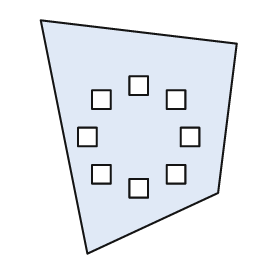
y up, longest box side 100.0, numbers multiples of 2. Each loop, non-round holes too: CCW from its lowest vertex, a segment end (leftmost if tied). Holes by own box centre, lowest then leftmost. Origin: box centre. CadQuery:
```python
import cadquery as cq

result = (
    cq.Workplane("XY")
    .moveTo(-22.0, -50.0)
    .lineTo(34.0, -24.0)
    .lineTo(42.0, 40.0)
    .lineTo(-42.0, 50.0)
    .close()
    .moveTo(-4.0, -26.0)
    .lineTo(4.0, -26.0)
    .lineTo(4.0, -18.0)
    .lineTo(-4.0, -18.0)
    .close()
    .moveTo(-20.0, -20.0)
    .lineTo(-12.0, -20.0)
    .lineTo(-12.0, -12.0)
    .lineTo(-20.0, -12.0)
    .close()
    .moveTo(12.0, -20.0)
    .lineTo(20.0, -20.0)
    .lineTo(20.0, -12.0)
    .lineTo(12.0, -12.0)
    .close()
    .moveTo(-26.0, -4.0)
    .lineTo(-18.0, -4.0)
    .lineTo(-18.0, 4.0)
    .lineTo(-26.0, 4.0)
    .close()
    .moveTo(18.0, -4.0)
    .lineTo(26.0, -4.0)
    .lineTo(26.0, 4.0)
    .lineTo(18.0, 4.0)
    .close()
    .moveTo(-20.0, 12.0)
    .lineTo(-12.0, 12.0)
    .lineTo(-12.0, 20.0)
    .lineTo(-20.0, 20.0)
    .close()
    .moveTo(12.0, 12.0)
    .lineTo(20.0, 12.0)
    .lineTo(20.0, 20.0)
    .lineTo(12.0, 20.0)
    .close()
    .moveTo(-4.0, 18.0)
    .lineTo(4.0, 18.0)
    .lineTo(4.0, 26.0)
    .lineTo(-4.0, 26.0)
    .close()
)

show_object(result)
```